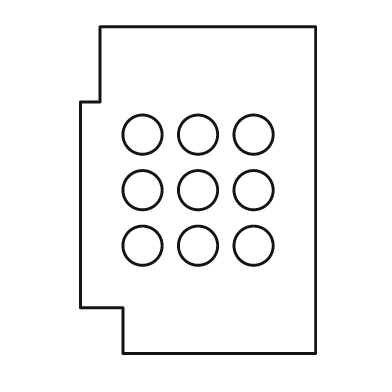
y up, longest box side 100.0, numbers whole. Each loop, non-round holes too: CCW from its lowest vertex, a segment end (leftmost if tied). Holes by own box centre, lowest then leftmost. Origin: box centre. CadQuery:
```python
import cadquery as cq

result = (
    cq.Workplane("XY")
    .moveTo(-23.0, -50.0)
    .lineTo(36.0, -50.0)
    .lineTo(36.0, 50.0)
    .lineTo(-30.0, 50.0)
    .lineTo(-30.0, 27.0)
    .lineTo(-36.0, 27.0)
    .lineTo(-36.0, -36.0)
    .lineTo(-23.0, -36.0)
    .close()
    .moveTo(-17.0, -17.0)
    .circle(6.0)
    .moveTo(0.0, -17.0)
    .circle(6.0)
    .moveTo(17.0, -17.0)
    .circle(6.0)
    .moveTo(-17.0, 0.0)
    .circle(6.0)
    .moveTo(0.0, 0.0)
    .circle(6.0)
    .moveTo(17.0, 0.0)
    .circle(6.0)
    .moveTo(-17.0, 17.0)
    .circle(6.0)
    .moveTo(0.0, 17.0)
    .circle(6.0)
    .moveTo(17.0, 17.0)
    .circle(6.0)
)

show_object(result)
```